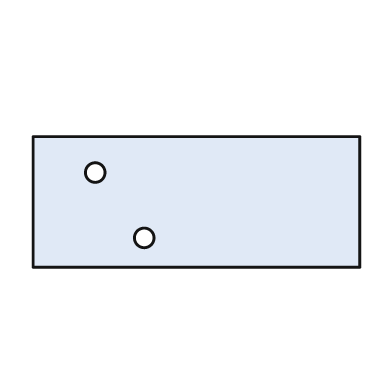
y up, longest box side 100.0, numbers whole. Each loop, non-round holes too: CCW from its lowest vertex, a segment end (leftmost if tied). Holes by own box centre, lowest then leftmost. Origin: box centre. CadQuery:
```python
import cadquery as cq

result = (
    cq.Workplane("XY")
    .moveTo(-50.0, -20.0)
    .lineTo(50.0, -20.0)
    .lineTo(50.0, 20.0)
    .lineTo(-50.0, 20.0)
    .close()
    .moveTo(-16.0, -11.0)
    .circle(3.0)
    .moveTo(-31.0, 9.0)
    .circle(3.0)
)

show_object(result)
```